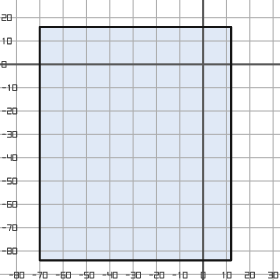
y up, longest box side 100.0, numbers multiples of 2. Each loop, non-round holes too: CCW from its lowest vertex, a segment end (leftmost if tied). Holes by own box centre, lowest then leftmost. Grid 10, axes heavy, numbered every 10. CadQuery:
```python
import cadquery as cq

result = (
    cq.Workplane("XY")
    .moveTo(-70.0, -84.0)
    .lineTo(12.0, -84.0)
    .lineTo(12.0, 16.0)
    .lineTo(-70.0, 16.0)
    .close()
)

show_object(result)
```